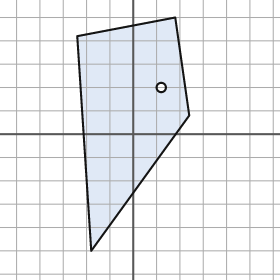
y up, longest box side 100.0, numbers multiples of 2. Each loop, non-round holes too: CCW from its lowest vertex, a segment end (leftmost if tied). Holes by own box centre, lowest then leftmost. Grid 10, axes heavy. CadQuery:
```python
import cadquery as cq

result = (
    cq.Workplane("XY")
    .moveTo(-18.0, -50.0)
    .lineTo(24.0, 8.0)
    .lineTo(18.0, 50.0)
    .lineTo(-24.0, 42.0)
    .close()
    .moveTo(12.0, 20.0)
    .circle(2.0)
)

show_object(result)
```